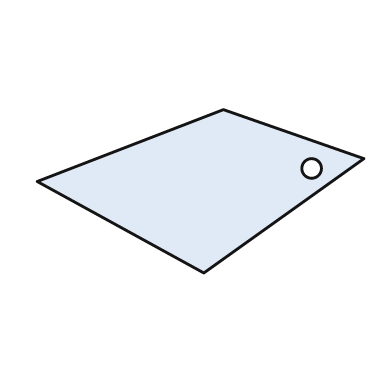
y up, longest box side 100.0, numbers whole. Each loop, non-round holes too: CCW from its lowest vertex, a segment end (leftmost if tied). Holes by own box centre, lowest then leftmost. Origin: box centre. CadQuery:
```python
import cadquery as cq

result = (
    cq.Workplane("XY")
    .moveTo(1.0, -25.0)
    .lineTo(50.0, 10.0)
    .lineTo(7.0, 25.0)
    .lineTo(-50.0, 3.0)
    .close()
    .moveTo(34.0, 7.0)
    .circle(3.0)
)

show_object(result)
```